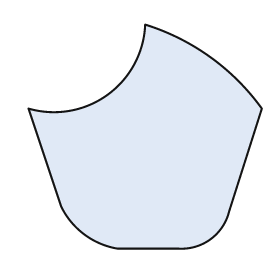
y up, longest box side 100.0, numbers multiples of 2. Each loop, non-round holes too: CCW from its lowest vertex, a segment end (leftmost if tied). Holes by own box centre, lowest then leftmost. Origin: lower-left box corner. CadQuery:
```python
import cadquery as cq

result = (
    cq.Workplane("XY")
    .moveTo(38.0, 0.0)
    .lineTo(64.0, 0.0)
    .threePointArc((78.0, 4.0), (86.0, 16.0))
    .lineTo(100.0, 60.0)
    .threePointArc((78.0, 82.0), (50.0, 96.0))
    .threePointArc((34.0, 66.0), (0.0, 60.0))
    .lineTo(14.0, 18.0)
    .threePointArc((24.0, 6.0), (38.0, 0.0))
    .close()
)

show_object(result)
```